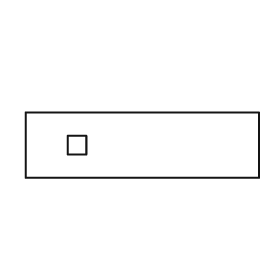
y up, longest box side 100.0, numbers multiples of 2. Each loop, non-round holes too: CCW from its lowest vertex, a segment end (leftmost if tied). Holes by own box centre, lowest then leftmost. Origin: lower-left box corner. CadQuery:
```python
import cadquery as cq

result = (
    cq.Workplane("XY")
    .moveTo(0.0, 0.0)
    .lineTo(100.0, 0.0)
    .lineTo(100.0, 28.0)
    .lineTo(0.0, 28.0)
    .close()
    .moveTo(18.0, 10.0)
    .lineTo(26.0, 10.0)
    .lineTo(26.0, 18.0)
    .lineTo(18.0, 18.0)
    .close()
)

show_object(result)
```